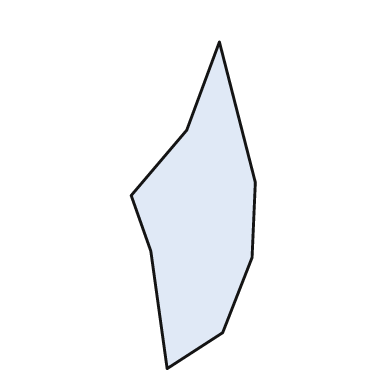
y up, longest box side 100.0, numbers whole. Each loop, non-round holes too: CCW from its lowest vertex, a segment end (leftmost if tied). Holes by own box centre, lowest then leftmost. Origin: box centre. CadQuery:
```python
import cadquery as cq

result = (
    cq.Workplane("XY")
    .moveTo(-8.0, -50.0)
    .lineTo(9.0, -39.0)
    .lineTo(18.0, -16.0)
    .lineTo(19.0, 7.0)
    .lineTo(8.0, 50.0)
    .lineTo(-2.0, 23.0)
    .lineTo(-19.0, 3.0)
    .lineTo(-13.0, -14.0)
    .close()
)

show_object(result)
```